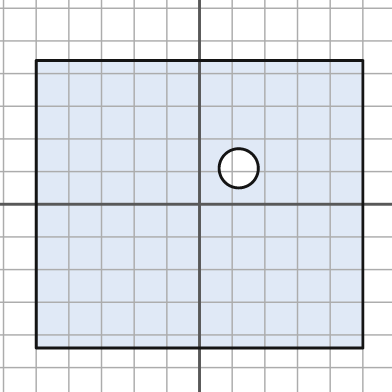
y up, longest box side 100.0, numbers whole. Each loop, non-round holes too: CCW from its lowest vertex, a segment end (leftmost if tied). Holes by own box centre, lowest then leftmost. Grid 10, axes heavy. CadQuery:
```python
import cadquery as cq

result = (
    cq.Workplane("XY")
    .moveTo(-50.0, -44.0)
    .lineTo(50.0, -44.0)
    .lineTo(50.0, 44.0)
    .lineTo(-50.0, 44.0)
    .close()
    .moveTo(12.0, 11.0)
    .circle(6.0)
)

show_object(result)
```